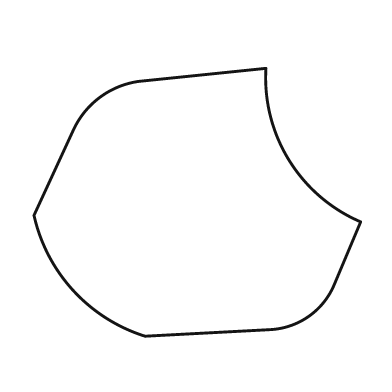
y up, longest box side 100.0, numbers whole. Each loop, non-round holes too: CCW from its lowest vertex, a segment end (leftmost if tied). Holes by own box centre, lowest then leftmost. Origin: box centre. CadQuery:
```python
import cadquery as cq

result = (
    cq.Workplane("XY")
    .moveTo(-16.0, -41.0)
    .lineTo(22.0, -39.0)
    .threePointArc((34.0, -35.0), (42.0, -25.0))
    .lineTo(50.0, -6.0)
    .threePointArc((28.0, 13.0), (21.0, 41.0))
    .lineTo(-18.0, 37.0)
    .threePointArc((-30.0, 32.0), (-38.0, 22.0))
    .lineTo(-50.0, -4.0)
    .threePointArc((-38.0, -27.0), (-16.0, -41.0))
    .close()
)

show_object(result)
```